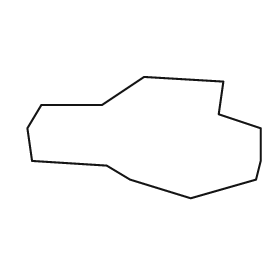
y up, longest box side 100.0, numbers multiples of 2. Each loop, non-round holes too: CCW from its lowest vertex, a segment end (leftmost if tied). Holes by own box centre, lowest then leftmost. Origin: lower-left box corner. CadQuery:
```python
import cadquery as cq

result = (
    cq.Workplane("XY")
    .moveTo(70.0, 0.0)
    .lineTo(98.0, 8.0)
    .lineTo(100.0, 16.0)
    .lineTo(100.0, 30.0)
    .lineTo(82.0, 36.0)
    .lineTo(84.0, 50.0)
    .lineTo(50.0, 52.0)
    .lineTo(32.0, 40.0)
    .lineTo(6.0, 40.0)
    .lineTo(0.0, 30.0)
    .lineTo(2.0, 16.0)
    .lineTo(34.0, 14.0)
    .lineTo(44.0, 8.0)
    .close()
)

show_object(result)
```